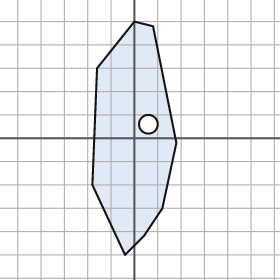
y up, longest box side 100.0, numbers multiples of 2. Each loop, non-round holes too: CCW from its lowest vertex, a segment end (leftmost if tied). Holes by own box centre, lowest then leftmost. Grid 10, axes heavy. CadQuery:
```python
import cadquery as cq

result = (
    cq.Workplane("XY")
    .moveTo(-4.0, -50.0)
    .lineTo(4.0, -42.0)
    .lineTo(12.0, -30.0)
    .lineTo(18.0, -2.0)
    .lineTo(8.0, 48.0)
    .lineTo(0.0, 50.0)
    .lineTo(-16.0, 30.0)
    .lineTo(-18.0, -20.0)
    .close()
    .moveTo(6.0, 6.0)
    .circle(4.0)
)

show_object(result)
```